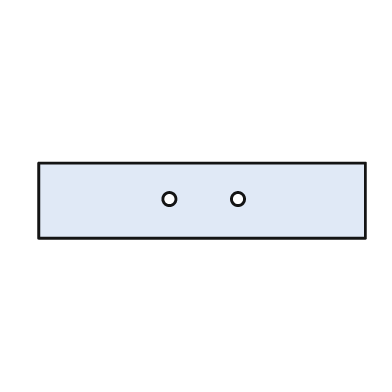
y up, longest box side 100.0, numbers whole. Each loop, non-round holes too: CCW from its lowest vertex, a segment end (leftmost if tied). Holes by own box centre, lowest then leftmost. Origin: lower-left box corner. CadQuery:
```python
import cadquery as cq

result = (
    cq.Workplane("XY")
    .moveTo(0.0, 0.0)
    .lineTo(100.0, 0.0)
    .lineTo(100.0, 23.0)
    .lineTo(0.0, 23.0)
    .close()
    .moveTo(40.0, 12.0)
    .circle(2.0)
    .moveTo(61.0, 12.0)
    .circle(2.0)
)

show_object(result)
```